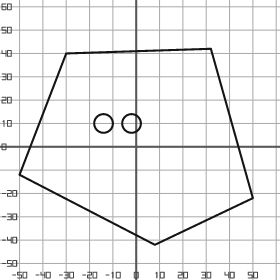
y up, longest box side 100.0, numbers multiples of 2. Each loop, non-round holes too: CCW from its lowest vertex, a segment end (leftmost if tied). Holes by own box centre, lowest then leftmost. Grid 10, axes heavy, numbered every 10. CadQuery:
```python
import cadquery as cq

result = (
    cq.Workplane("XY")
    .moveTo(8.0, -42.0)
    .lineTo(50.0, -22.0)
    .lineTo(32.0, 42.0)
    .lineTo(-30.0, 40.0)
    .lineTo(-50.0, -12.0)
    .close()
    .moveTo(-14.0, 10.0)
    .circle(4.0)
    .moveTo(-2.0, 10.0)
    .circle(4.0)
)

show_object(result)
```